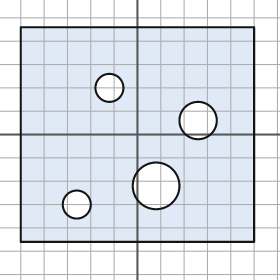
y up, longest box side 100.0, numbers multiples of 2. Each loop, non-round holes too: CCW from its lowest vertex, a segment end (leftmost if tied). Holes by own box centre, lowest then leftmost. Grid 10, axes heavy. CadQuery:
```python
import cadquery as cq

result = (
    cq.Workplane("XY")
    .moveTo(-50.0, -46.0)
    .lineTo(50.0, -46.0)
    .lineTo(50.0, 46.0)
    .lineTo(-50.0, 46.0)
    .close()
    .moveTo(-26.0, -30.0)
    .circle(6.0)
    .moveTo(8.0, -22.0)
    .circle(10.0)
    .moveTo(26.0, 6.0)
    .circle(8.0)
    .moveTo(-12.0, 20.0)
    .circle(6.0)
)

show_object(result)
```